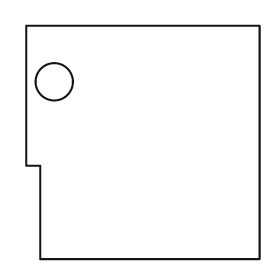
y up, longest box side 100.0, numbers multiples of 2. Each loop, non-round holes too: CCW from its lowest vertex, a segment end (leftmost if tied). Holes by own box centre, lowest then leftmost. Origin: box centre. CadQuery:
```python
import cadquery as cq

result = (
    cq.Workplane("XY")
    .moveTo(-44.0, -50.0)
    .lineTo(50.0, -50.0)
    .lineTo(50.0, 50.0)
    .lineTo(-50.0, 50.0)
    .lineTo(-50.0, -10.0)
    .lineTo(-44.0, -10.0)
    .close()
    .moveTo(-38.0, 26.0)
    .circle(8.0)
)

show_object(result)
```